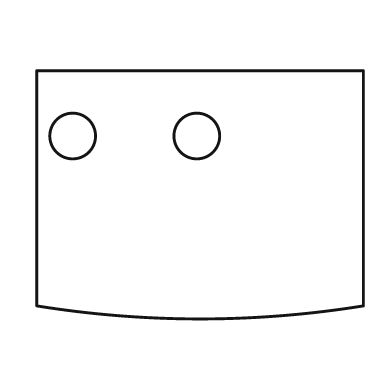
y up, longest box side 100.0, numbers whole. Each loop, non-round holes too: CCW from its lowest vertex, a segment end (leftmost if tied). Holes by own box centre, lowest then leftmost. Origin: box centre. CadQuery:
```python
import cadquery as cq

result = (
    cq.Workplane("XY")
    .moveTo(-50.0, -34.0)
    .threePointArc((0.0, -38.0), (50.0, -34.0))
    .lineTo(50.0, 38.0)
    .lineTo(-50.0, 38.0)
    .close()
    .moveTo(-39.0, 18.0)
    .circle(7.0)
    .moveTo(-1.0, 18.0)
    .circle(7.0)
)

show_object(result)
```